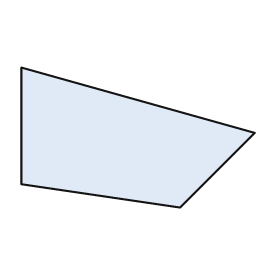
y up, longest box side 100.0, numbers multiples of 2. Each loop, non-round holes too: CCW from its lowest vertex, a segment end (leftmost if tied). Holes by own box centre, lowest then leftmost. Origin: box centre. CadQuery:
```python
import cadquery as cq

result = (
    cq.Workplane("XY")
    .moveTo(18.0, -30.0)
    .lineTo(50.0, 2.0)
    .lineTo(-50.0, 30.0)
    .lineTo(-50.0, -20.0)
    .close()
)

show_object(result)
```